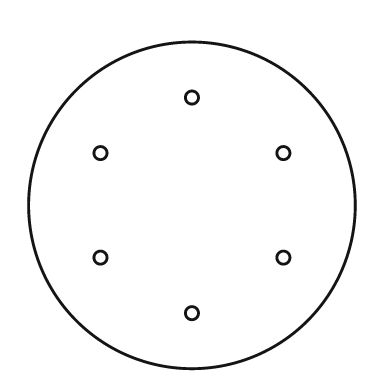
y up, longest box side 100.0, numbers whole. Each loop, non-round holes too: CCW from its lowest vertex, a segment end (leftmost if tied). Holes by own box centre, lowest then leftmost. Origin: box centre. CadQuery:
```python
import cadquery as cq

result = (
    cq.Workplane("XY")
    .moveTo(0.0, 0.0)
    .circle(50.0)
    .moveTo(0.0, -33.0)
    .circle(2.0)
    .moveTo(-28.0, -16.0)
    .circle(2.0)
    .moveTo(28.0, -16.0)
    .circle(2.0)
    .moveTo(-28.0, 16.0)
    .circle(2.0)
    .moveTo(28.0, 16.0)
    .circle(2.0)
    .moveTo(0.0, 33.0)
    .circle(2.0)
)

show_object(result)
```